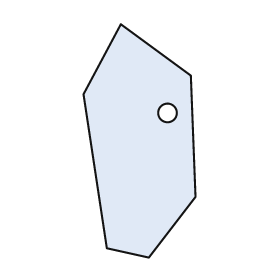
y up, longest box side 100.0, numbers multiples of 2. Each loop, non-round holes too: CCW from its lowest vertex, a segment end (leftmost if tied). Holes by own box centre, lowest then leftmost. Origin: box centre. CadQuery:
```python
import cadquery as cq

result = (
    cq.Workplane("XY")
    .moveTo(4.0, -50.0)
    .lineTo(24.0, -24.0)
    .lineTo(22.0, 28.0)
    .lineTo(-8.0, 50.0)
    .lineTo(-24.0, 20.0)
    .lineTo(-14.0, -46.0)
    .close()
    .moveTo(12.0, 12.0)
    .circle(4.0)
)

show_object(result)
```